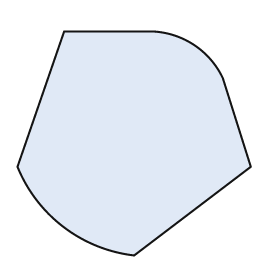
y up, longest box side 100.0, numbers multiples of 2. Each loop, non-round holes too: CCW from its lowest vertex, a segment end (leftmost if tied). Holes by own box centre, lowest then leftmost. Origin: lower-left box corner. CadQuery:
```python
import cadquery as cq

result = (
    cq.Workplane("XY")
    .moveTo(50.0, 0.0)
    .lineTo(100.0, 38.0)
    .lineTo(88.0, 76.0)
    .threePointArc((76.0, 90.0), (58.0, 96.0))
    .lineTo(20.0, 96.0)
    .lineTo(0.0, 38.0)
    .threePointArc((20.0, 12.0), (50.0, 0.0))
    .close()
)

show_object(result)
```